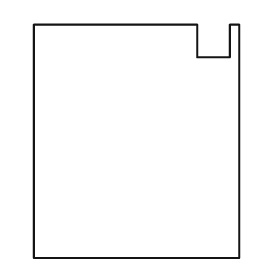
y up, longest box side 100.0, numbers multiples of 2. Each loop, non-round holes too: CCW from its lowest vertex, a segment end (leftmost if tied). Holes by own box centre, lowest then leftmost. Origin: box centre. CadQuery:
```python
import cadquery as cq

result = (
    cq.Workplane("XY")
    .moveTo(-44.0, -50.0)
    .lineTo(44.0, -50.0)
    .lineTo(44.0, 50.0)
    .lineTo(40.0, 50.0)
    .lineTo(40.0, 36.0)
    .lineTo(26.0, 36.0)
    .lineTo(26.0, 50.0)
    .lineTo(-44.0, 50.0)
    .close()
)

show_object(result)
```